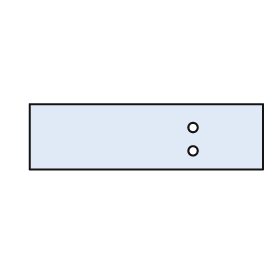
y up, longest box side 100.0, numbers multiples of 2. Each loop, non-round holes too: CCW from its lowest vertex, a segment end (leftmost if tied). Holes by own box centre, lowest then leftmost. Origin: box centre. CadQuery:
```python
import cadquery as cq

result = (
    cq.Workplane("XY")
    .moveTo(-50.0, -14.0)
    .lineTo(50.0, -14.0)
    .lineTo(50.0, 14.0)
    .lineTo(-50.0, 14.0)
    .close()
    .moveTo(20.0, -6.0)
    .circle(2.0)
    .moveTo(20.0, 4.0)
    .circle(2.0)
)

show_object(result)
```